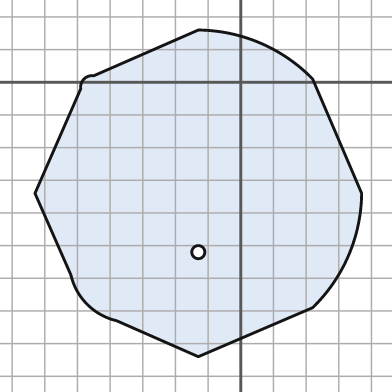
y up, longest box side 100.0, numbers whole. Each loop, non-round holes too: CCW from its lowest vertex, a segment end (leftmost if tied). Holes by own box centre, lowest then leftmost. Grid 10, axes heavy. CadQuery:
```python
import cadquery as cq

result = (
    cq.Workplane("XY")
    .moveTo(-13.0, -84.0)
    .lineTo(22.0, -69.0)
    .threePointArc((33.0, -53.0), (37.0, -34.0))
    .lineTo(22.0, 1.0)
    .threePointArc((6.0, 12.0), (-13.0, 16.0))
    .lineTo(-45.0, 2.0)
    .threePointArc((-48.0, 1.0), (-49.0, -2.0))
    .lineTo(-63.0, -34.0)
    .lineTo(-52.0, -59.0)
    .threePointArc((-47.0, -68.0), (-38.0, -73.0))
    .close()
    .moveTo(-13.0, -52.0)
    .circle(2.0)
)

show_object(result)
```